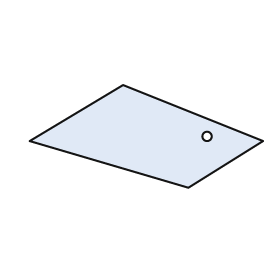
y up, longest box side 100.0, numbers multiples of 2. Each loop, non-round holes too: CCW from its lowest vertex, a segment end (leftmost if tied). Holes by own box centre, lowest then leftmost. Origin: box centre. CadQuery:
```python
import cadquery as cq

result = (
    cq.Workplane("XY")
    .moveTo(18.0, -22.0)
    .lineTo(50.0, -2.0)
    .lineTo(-10.0, 22.0)
    .lineTo(-50.0, -2.0)
    .close()
    .moveTo(26.0, 0.0)
    .circle(2.0)
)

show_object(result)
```